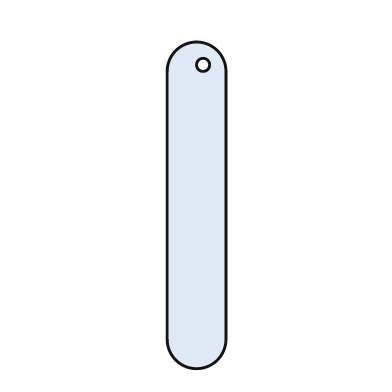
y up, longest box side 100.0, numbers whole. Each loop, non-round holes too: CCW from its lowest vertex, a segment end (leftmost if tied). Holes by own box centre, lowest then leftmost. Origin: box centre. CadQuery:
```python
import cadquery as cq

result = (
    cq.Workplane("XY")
    .moveTo(-9.0, -41.0)
    .threePointArc((0.0, -50.0), (9.0, -41.0))
    .lineTo(9.0, 41.0)
    .threePointArc((0.0, 50.0), (-9.0, 41.0))
    .close()
    .moveTo(2.0, 43.0)
    .circle(2.0)
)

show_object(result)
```